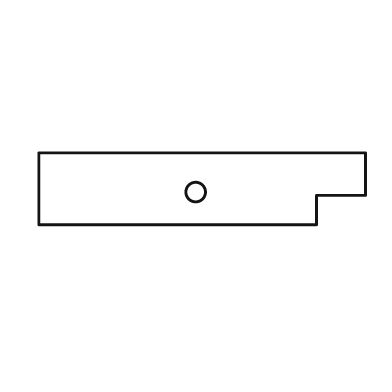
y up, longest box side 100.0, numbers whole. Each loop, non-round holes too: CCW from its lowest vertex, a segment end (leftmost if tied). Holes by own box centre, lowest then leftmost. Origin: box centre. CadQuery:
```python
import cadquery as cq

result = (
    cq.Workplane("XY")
    .moveTo(-50.0, -11.0)
    .lineTo(35.0, -11.0)
    .lineTo(35.0, -2.0)
    .lineTo(50.0, -2.0)
    .lineTo(50.0, 11.0)
    .lineTo(-50.0, 11.0)
    .close()
    .moveTo(-2.0, -1.0)
    .circle(3.0)
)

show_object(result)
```